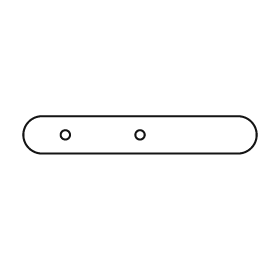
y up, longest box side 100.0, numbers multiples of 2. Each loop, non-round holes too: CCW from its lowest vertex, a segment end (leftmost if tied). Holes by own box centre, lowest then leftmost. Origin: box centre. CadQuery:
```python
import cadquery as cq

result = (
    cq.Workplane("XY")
    .moveTo(-42.0, -8.0)
    .lineTo(42.0, -8.0)
    .threePointArc((50.0, 0.0), (42.0, 8.0))
    .lineTo(-42.0, 8.0)
    .threePointArc((-50.0, 0.0), (-42.0, -8.0))
    .close()
    .moveTo(-32.0, 0.0)
    .circle(2.0)
    .moveTo(0.0, 0.0)
    .circle(2.0)
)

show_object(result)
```